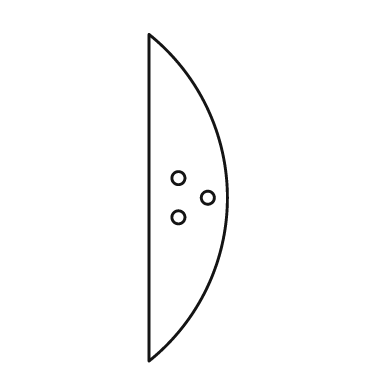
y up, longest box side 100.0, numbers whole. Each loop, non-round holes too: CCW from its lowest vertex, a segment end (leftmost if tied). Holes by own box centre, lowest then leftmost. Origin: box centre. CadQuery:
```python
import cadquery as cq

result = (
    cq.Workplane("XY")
    .moveTo(-12.0, -50.0)
    .threePointArc((12.0, 0.0), (-12.0, 50.0))
    .close()
    .moveTo(-3.0, -6.0)
    .circle(2.0)
    .moveTo(6.0, 0.0)
    .circle(2.0)
    .moveTo(-3.0, 6.0)
    .circle(2.0)
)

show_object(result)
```